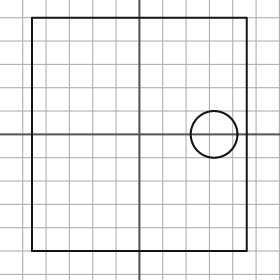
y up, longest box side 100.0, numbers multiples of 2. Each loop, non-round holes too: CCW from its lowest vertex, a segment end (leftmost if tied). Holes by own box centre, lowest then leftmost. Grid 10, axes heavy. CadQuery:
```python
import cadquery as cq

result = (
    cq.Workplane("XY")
    .moveTo(-46.0, -50.0)
    .lineTo(46.0, -50.0)
    .lineTo(46.0, 50.0)
    .lineTo(-46.0, 50.0)
    .close()
    .moveTo(32.0, 0.0)
    .circle(10.0)
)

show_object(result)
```